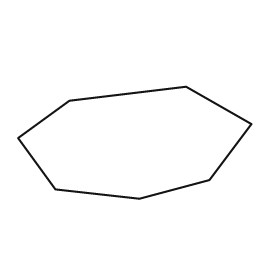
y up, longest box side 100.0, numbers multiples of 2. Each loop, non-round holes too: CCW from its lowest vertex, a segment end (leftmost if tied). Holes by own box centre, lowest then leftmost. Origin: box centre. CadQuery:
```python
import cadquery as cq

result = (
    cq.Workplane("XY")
    .moveTo(2.0, -24.0)
    .lineTo(32.0, -16.0)
    .lineTo(50.0, 8.0)
    .lineTo(22.0, 24.0)
    .lineTo(-28.0, 18.0)
    .lineTo(-50.0, 2.0)
    .lineTo(-34.0, -20.0)
    .close()
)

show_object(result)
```